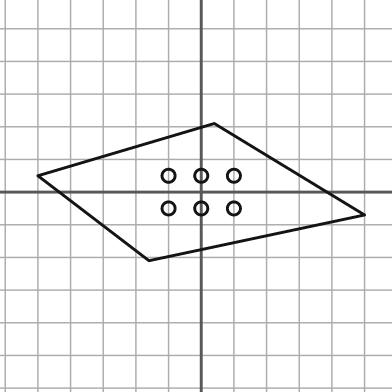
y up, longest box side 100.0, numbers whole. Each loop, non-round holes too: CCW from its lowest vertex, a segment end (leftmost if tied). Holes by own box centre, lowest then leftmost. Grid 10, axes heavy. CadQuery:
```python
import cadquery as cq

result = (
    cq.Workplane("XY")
    .moveTo(-16.0, -21.0)
    .lineTo(50.0, -7.0)
    .lineTo(4.0, 21.0)
    .lineTo(-50.0, 5.0)
    .close()
    .moveTo(-10.0, -5.0)
    .circle(2.0)
    .moveTo(0.0, -5.0)
    .circle(2.0)
    .moveTo(10.0, -5.0)
    .circle(2.0)
    .moveTo(-10.0, 5.0)
    .circle(2.0)
    .moveTo(0.0, 5.0)
    .circle(2.0)
    .moveTo(10.0, 5.0)
    .circle(2.0)
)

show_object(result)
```